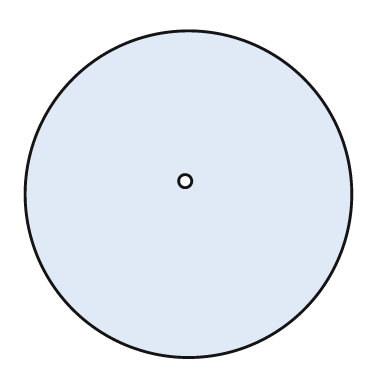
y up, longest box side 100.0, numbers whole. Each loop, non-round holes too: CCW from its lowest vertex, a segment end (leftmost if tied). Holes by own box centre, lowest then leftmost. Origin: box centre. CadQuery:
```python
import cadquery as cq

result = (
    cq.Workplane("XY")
    .moveTo(0.0, 0.0)
    .circle(50.0)
    .moveTo(-1.0, 4.0)
    .circle(2.0)
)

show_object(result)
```